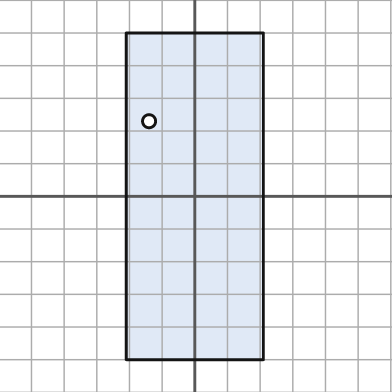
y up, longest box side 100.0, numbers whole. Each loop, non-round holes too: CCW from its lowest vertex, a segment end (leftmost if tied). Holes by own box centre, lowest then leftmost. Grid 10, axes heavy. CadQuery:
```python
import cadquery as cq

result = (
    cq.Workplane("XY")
    .moveTo(-21.0, -50.0)
    .lineTo(21.0, -50.0)
    .lineTo(21.0, 50.0)
    .lineTo(-21.0, 50.0)
    .close()
    .moveTo(-14.0, 23.0)
    .circle(2.0)
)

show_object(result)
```